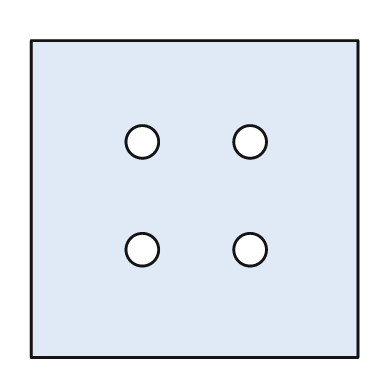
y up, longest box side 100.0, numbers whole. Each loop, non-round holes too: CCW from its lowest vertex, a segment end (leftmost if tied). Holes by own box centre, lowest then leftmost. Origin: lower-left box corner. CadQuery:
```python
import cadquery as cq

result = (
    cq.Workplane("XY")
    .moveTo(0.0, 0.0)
    .lineTo(100.0, 0.0)
    .lineTo(100.0, 97.0)
    .lineTo(0.0, 97.0)
    .close()
    .moveTo(34.0, 33.0)
    .circle(5.0)
    .moveTo(67.0, 33.0)
    .circle(5.0)
    .moveTo(34.0, 66.0)
    .circle(5.0)
    .moveTo(67.0, 66.0)
    .circle(5.0)
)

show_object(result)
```